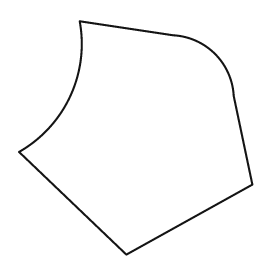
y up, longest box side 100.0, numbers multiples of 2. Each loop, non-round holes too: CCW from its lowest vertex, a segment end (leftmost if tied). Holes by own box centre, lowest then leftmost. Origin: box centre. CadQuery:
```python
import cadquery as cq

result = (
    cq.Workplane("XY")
    .moveTo(-4.0, -50.0)
    .lineTo(50.0, -20.0)
    .lineTo(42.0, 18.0)
    .threePointArc((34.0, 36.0), (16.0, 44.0))
    .lineTo(-24.0, 50.0)
    .threePointArc((-28.0, 18.0), (-50.0, -6.0))
    .close()
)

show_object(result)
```